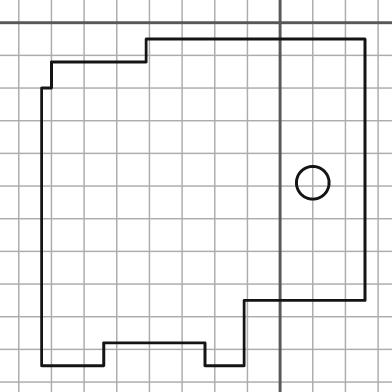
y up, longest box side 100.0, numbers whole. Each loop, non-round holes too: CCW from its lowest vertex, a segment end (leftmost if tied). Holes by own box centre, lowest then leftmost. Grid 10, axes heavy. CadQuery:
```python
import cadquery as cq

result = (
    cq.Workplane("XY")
    .moveTo(-73.0, -105.0)
    .lineTo(-54.0, -105.0)
    .lineTo(-54.0, -98.0)
    .lineTo(-23.0, -98.0)
    .lineTo(-23.0, -105.0)
    .lineTo(-11.0, -105.0)
    .lineTo(-11.0, -85.0)
    .lineTo(26.0, -85.0)
    .lineTo(26.0, -5.0)
    .lineTo(-41.0, -5.0)
    .lineTo(-41.0, -12.0)
    .lineTo(-70.0, -12.0)
    .lineTo(-70.0, -20.0)
    .lineTo(-73.0, -20.0)
    .close()
    .moveTo(10.0, -49.0)
    .circle(5.0)
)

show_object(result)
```